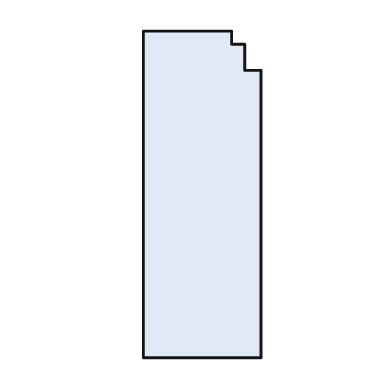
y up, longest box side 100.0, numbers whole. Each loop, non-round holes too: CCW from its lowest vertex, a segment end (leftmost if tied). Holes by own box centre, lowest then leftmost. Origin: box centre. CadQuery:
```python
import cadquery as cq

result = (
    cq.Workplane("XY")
    .moveTo(-18.0, -50.0)
    .lineTo(18.0, -50.0)
    .lineTo(18.0, 38.0)
    .lineTo(13.0, 38.0)
    .lineTo(13.0, 46.0)
    .lineTo(9.0, 46.0)
    .lineTo(9.0, 50.0)
    .lineTo(-18.0, 50.0)
    .close()
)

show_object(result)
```